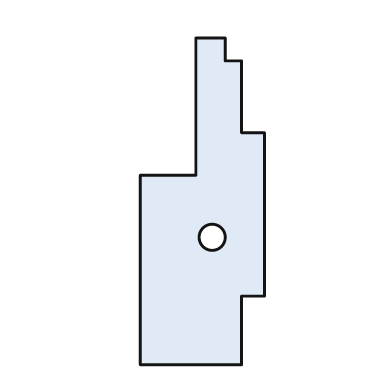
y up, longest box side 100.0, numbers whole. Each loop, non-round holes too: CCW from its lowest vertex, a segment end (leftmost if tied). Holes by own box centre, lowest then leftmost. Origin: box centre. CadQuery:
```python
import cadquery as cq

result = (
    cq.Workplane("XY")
    .moveTo(-19.0, -50.0)
    .lineTo(12.0, -50.0)
    .lineTo(12.0, -29.0)
    .lineTo(19.0, -29.0)
    .lineTo(19.0, 21.0)
    .lineTo(12.0, 21.0)
    .lineTo(12.0, 43.0)
    .lineTo(7.0, 43.0)
    .lineTo(7.0, 50.0)
    .lineTo(-2.0, 50.0)
    .lineTo(-2.0, 8.0)
    .lineTo(-19.0, 8.0)
    .close()
    .moveTo(3.0, -11.0)
    .circle(4.0)
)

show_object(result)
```